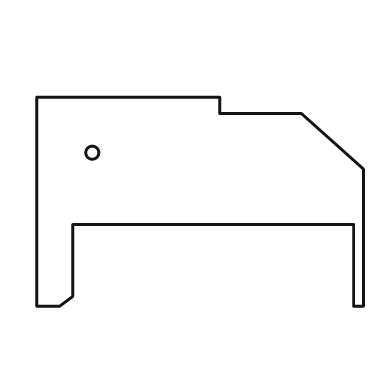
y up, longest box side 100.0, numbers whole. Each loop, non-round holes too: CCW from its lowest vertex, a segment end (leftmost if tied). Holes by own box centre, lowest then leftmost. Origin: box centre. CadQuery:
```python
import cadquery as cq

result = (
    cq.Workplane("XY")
    .moveTo(-50.0, -32.0)
    .lineTo(-43.0, -32.0)
    .lineTo(-39.0, -29.0)
    .lineTo(-39.0, -7.0)
    .lineTo(47.0, -7.0)
    .lineTo(47.0, -32.0)
    .lineTo(50.0, -32.0)
    .lineTo(50.0, 10.0)
    .lineTo(31.0, 27.0)
    .lineTo(6.0, 27.0)
    .lineTo(6.0, 32.0)
    .lineTo(-50.0, 32.0)
    .close()
    .moveTo(-33.0, 15.0)
    .circle(2.0)
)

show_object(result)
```